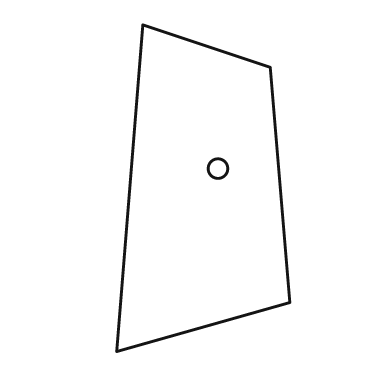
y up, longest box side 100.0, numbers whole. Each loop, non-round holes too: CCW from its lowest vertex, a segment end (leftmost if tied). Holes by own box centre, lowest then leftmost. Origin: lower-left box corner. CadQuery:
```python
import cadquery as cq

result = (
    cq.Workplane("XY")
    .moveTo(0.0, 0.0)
    .lineTo(53.0, 15.0)
    .lineTo(47.0, 87.0)
    .lineTo(8.0, 100.0)
    .close()
    .moveTo(31.0, 56.0)
    .circle(3.0)
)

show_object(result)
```